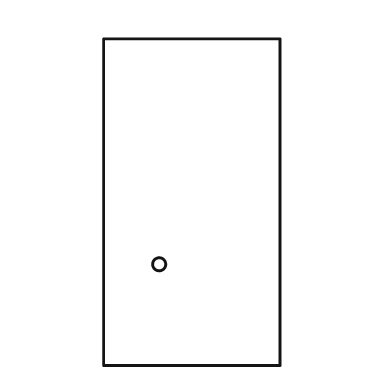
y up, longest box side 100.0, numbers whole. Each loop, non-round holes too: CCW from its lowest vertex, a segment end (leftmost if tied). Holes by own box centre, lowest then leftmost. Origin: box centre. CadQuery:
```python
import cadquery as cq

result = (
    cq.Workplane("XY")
    .moveTo(-27.0, -50.0)
    .lineTo(27.0, -50.0)
    .lineTo(27.0, 50.0)
    .lineTo(-27.0, 50.0)
    .close()
    .moveTo(-10.0, -19.0)
    .circle(2.0)
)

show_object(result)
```